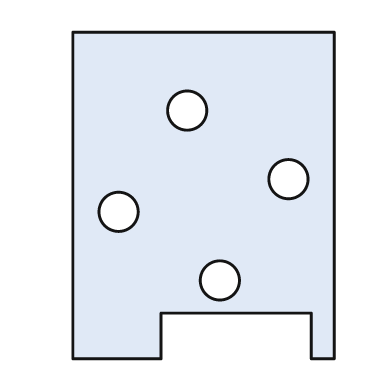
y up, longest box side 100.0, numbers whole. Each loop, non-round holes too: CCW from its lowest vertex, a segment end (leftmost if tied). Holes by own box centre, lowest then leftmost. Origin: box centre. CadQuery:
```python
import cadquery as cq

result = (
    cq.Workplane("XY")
    .moveTo(-40.0, -50.0)
    .lineTo(-13.0, -50.0)
    .lineTo(-13.0, -36.0)
    .lineTo(33.0, -36.0)
    .lineTo(33.0, -50.0)
    .lineTo(40.0, -50.0)
    .lineTo(40.0, 50.0)
    .lineTo(-40.0, 50.0)
    .close()
    .moveTo(5.0, -26.0)
    .circle(6.0)
    .moveTo(-26.0, -5.0)
    .circle(6.0)
    .moveTo(26.0, 5.0)
    .circle(6.0)
    .moveTo(-5.0, 26.0)
    .circle(6.0)
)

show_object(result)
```